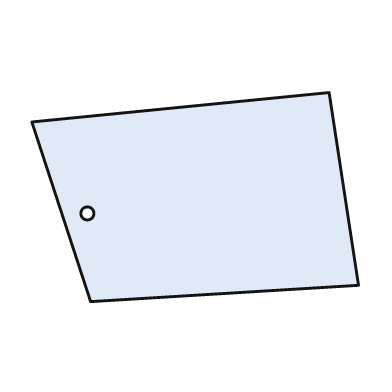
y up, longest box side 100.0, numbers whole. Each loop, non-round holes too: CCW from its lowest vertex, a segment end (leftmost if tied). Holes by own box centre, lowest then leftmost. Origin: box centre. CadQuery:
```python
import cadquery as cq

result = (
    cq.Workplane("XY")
    .moveTo(-32.0, -32.0)
    .lineTo(50.0, -27.0)
    .lineTo(41.0, 32.0)
    .lineTo(-50.0, 23.0)
    .close()
    .moveTo(-33.0, -5.0)
    .circle(2.0)
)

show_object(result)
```